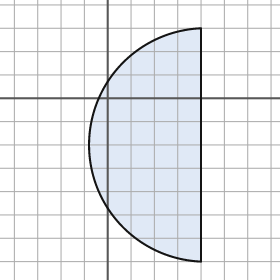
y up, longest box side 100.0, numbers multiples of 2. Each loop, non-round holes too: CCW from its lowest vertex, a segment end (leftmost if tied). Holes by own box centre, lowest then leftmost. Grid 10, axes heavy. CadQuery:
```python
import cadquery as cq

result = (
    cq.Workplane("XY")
    .moveTo(40.0, -70.0)
    .lineTo(40.0, 30.0)
    .threePointArc((-8.0, -20.0), (40.0, -70.0))
    .close()
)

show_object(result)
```